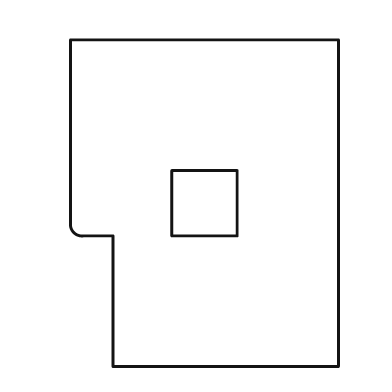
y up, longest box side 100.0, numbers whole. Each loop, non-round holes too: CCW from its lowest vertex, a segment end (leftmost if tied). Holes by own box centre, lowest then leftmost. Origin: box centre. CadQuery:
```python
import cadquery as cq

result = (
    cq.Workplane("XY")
    .moveTo(-28.0, -50.0)
    .lineTo(41.0, -50.0)
    .lineTo(41.0, 50.0)
    .lineTo(-41.0, 50.0)
    .lineTo(-41.0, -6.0)
    .threePointArc((-40.0, -9.0), (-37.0, -10.0))
    .lineTo(-28.0, -10.0)
    .close()
    .moveTo(-10.0, -10.0)
    .lineTo(10.0, -10.0)
    .lineTo(10.0, 10.0)
    .lineTo(-10.0, 10.0)
    .close()
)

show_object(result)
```